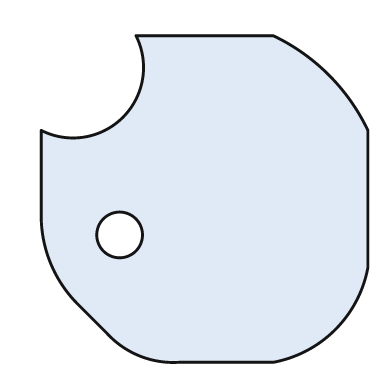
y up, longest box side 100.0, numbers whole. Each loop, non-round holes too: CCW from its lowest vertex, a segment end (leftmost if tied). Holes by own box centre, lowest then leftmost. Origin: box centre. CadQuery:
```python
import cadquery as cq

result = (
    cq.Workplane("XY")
    .moveTo(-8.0, -50.0)
    .lineTo(21.0, -50.0)
    .threePointArc((40.0, -40.0), (50.0, -21.0))
    .lineTo(50.0, 21.0)
    .threePointArc((38.0, 38.0), (21.0, 50.0))
    .lineTo(-21.0, 50.0)
    .threePointArc((-25.0, 25.0), (-50.0, 21.0))
    .lineTo(-50.0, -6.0)
    .threePointArc((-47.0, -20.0), (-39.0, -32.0))
    .lineTo(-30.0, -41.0)
    .threePointArc((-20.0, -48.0), (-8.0, -50.0))
    .close()
    .moveTo(-26.0, -11.0)
    .circle(7.0)
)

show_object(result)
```